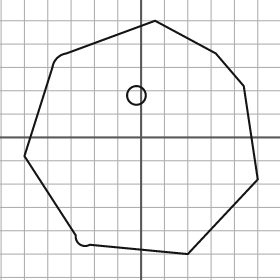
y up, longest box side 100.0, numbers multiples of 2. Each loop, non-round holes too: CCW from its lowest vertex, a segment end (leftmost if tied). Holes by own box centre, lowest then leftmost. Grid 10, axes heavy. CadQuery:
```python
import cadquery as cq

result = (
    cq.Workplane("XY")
    .moveTo(20.0, -50.0)
    .lineTo(50.0, -18.0)
    .lineTo(44.0, 22.0)
    .lineTo(32.0, 36.0)
    .lineTo(6.0, 50.0)
    .lineTo(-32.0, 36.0)
    .threePointArc((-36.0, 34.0), (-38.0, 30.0))
    .lineTo(-50.0, -8.0)
    .lineTo(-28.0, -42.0)
    .threePointArc((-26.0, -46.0), (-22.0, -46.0))
    .close()
    .moveTo(-2.0, 18.0)
    .circle(4.0)
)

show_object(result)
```